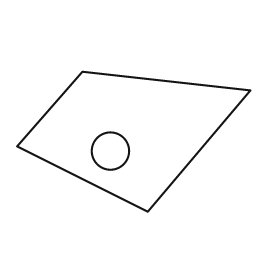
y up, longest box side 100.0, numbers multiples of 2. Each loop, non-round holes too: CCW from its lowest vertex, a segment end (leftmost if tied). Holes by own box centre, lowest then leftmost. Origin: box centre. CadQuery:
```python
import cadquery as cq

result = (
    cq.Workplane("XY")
    .moveTo(6.0, -30.0)
    .lineTo(50.0, 22.0)
    .lineTo(-22.0, 30.0)
    .lineTo(-50.0, -2.0)
    .close()
    .moveTo(-10.0, -4.0)
    .circle(8.0)
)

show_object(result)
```